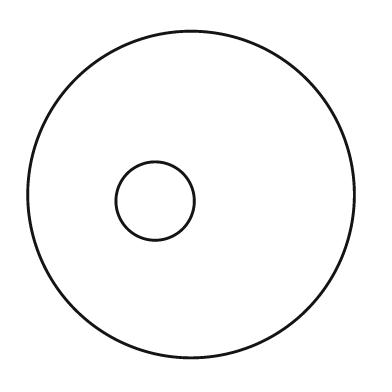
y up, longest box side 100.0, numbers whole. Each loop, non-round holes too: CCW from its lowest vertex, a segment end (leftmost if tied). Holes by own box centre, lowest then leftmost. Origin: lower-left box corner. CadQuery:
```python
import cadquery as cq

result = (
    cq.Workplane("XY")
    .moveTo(50.0, 50.0)
    .circle(50.0)
    .moveTo(39.0, 48.0)
    .circle(12.0)
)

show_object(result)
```